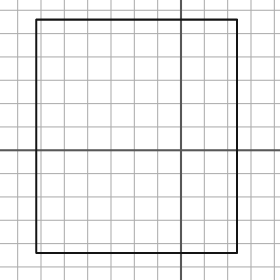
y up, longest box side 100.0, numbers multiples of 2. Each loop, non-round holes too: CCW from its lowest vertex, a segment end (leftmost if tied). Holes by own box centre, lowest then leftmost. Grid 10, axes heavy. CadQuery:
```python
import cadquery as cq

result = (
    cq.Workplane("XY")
    .moveTo(-62.0, -44.0)
    .lineTo(24.0, -44.0)
    .lineTo(24.0, 56.0)
    .lineTo(-62.0, 56.0)
    .close()
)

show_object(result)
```